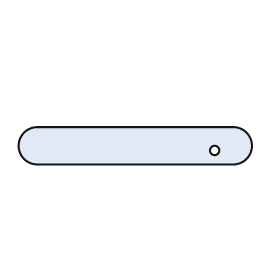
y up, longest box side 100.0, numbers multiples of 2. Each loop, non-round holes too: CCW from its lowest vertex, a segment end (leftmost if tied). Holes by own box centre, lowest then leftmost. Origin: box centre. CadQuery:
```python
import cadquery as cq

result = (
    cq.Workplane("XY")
    .moveTo(-42.0, -8.0)
    .lineTo(42.0, -8.0)
    .threePointArc((50.0, 0.0), (42.0, 8.0))
    .lineTo(-42.0, 8.0)
    .threePointArc((-50.0, 0.0), (-42.0, -8.0))
    .close()
    .moveTo(34.0, -2.0)
    .circle(2.0)
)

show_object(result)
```